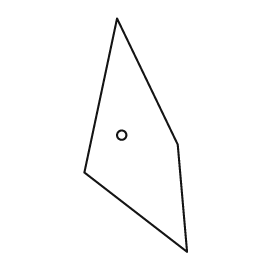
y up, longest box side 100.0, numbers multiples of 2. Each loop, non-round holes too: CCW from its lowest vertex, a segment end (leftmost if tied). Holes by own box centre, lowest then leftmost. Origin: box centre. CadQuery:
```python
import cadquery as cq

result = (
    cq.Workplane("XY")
    .moveTo(22.0, -50.0)
    .lineTo(18.0, -4.0)
    .lineTo(-8.0, 50.0)
    .lineTo(-22.0, -16.0)
    .close()
    .moveTo(-6.0, 0.0)
    .circle(2.0)
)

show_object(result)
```